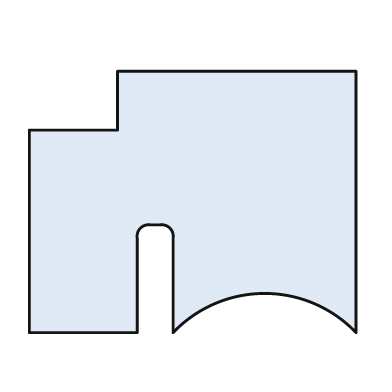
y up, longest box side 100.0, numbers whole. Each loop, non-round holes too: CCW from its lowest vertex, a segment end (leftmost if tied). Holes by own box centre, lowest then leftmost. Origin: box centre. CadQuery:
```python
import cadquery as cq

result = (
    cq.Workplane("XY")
    .moveTo(-50.0, -40.0)
    .lineTo(-17.0, -40.0)
    .lineTo(-17.0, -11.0)
    .threePointArc((-16.0, -8.0), (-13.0, -7.0))
    .lineTo(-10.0, -7.0)
    .threePointArc((-7.0, -8.0), (-6.0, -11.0))
    .lineTo(-6.0, -40.0)
    .threePointArc((22.0, -28.0), (50.0, -40.0))
    .lineTo(50.0, 40.0)
    .lineTo(-23.0, 40.0)
    .lineTo(-23.0, 22.0)
    .lineTo(-50.0, 22.0)
    .close()
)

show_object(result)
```